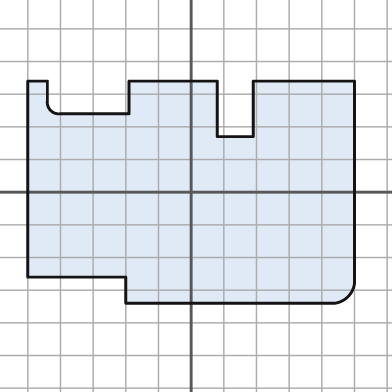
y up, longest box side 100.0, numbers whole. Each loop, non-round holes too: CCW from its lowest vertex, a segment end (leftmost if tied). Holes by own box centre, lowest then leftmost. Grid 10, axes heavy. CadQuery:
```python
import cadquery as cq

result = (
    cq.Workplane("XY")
    .moveTo(-20.0, -34.0)
    .lineTo(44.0, -34.0)
    .threePointArc((48.0, -32.0), (50.0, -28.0))
    .lineTo(50.0, 34.0)
    .lineTo(19.0, 34.0)
    .lineTo(19.0, 17.0)
    .lineTo(8.0, 17.0)
    .lineTo(8.0, 34.0)
    .lineTo(-19.0, 34.0)
    .lineTo(-19.0, 24.0)
    .lineTo(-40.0, 24.0)
    .threePointArc((-43.0, 25.0), (-44.0, 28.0))
    .lineTo(-44.0, 34.0)
    .lineTo(-50.0, 34.0)
    .lineTo(-50.0, -26.0)
    .lineTo(-20.0, -26.0)
    .close()
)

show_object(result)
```